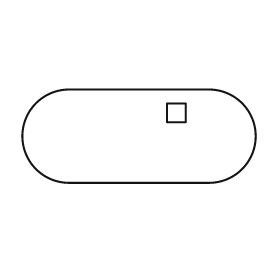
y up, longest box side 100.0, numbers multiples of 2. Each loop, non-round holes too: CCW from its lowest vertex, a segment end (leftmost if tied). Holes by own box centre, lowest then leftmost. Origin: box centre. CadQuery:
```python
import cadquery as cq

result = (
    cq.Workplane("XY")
    .moveTo(-30.0, -20.0)
    .lineTo(30.0, -20.0)
    .threePointArc((50.0, 0.0), (30.0, 20.0))
    .lineTo(-30.0, 20.0)
    .threePointArc((-50.0, 0.0), (-30.0, -20.0))
    .close()
    .moveTo(12.0, 6.0)
    .lineTo(20.0, 6.0)
    .lineTo(20.0, 14.0)
    .lineTo(12.0, 14.0)
    .close()
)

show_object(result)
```